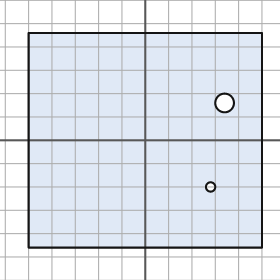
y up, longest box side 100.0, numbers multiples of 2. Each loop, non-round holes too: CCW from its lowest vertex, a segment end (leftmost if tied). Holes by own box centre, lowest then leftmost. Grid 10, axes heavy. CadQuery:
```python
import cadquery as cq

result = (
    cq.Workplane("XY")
    .moveTo(-50.0, -46.0)
    .lineTo(50.0, -46.0)
    .lineTo(50.0, 46.0)
    .lineTo(-50.0, 46.0)
    .close()
    .moveTo(28.0, -20.0)
    .circle(2.0)
    .moveTo(34.0, 16.0)
    .circle(4.0)
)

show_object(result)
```